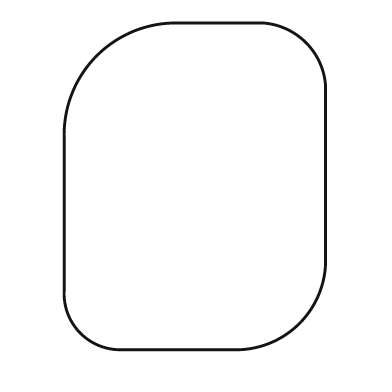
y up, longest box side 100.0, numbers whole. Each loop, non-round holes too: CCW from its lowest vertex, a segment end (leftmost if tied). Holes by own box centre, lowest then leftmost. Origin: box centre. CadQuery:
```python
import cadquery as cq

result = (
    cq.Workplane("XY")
    .moveTo(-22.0, -50.0)
    .lineTo(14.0, -50.0)
    .threePointArc((32.0, -42.0), (40.0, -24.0))
    .lineTo(40.0, 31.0)
    .threePointArc((34.0, 44.0), (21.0, 50.0))
    .lineTo(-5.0, 50.0)
    .threePointArc((-30.0, 40.0), (-40.0, 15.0))
    .lineTo(-40.0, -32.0)
    .threePointArc((-35.0, -45.0), (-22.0, -50.0))
    .close()
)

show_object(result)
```